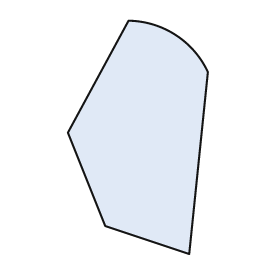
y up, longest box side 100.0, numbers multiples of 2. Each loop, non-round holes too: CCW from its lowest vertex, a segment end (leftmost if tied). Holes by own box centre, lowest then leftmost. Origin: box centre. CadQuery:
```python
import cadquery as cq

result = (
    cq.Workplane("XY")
    .moveTo(22.0, -50.0)
    .lineTo(30.0, 28.0)
    .threePointArc((16.0, 44.0), (-4.0, 50.0))
    .lineTo(-30.0, 2.0)
    .lineTo(-14.0, -38.0)
    .close()
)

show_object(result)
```